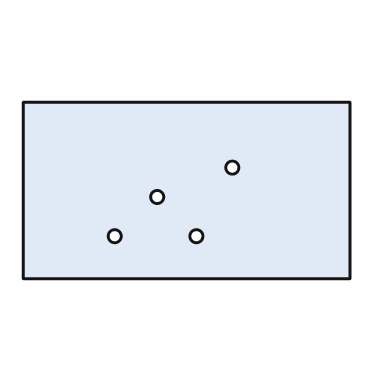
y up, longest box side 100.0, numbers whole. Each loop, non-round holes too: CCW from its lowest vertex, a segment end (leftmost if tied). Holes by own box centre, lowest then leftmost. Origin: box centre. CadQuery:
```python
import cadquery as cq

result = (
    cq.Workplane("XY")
    .moveTo(-50.0, -27.0)
    .lineTo(50.0, -27.0)
    .lineTo(50.0, 27.0)
    .lineTo(-50.0, 27.0)
    .close()
    .moveTo(-22.0, -14.0)
    .circle(2.0)
    .moveTo(3.0, -14.0)
    .circle(2.0)
    .moveTo(-9.0, -2.0)
    .circle(2.0)
    .moveTo(14.0, 7.0)
    .circle(2.0)
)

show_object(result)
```